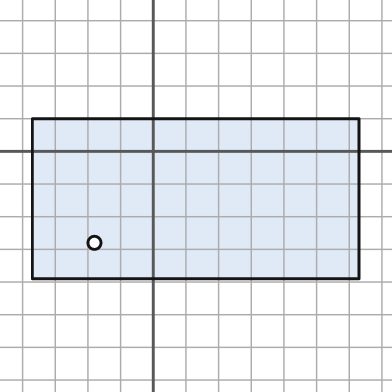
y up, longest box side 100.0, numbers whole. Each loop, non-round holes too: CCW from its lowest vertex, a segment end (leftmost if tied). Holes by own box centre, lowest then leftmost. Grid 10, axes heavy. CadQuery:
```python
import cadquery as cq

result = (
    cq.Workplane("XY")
    .moveTo(-37.0, -39.0)
    .lineTo(63.0, -39.0)
    .lineTo(63.0, 10.0)
    .lineTo(-37.0, 10.0)
    .close()
    .moveTo(-18.0, -28.0)
    .circle(2.0)
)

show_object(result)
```